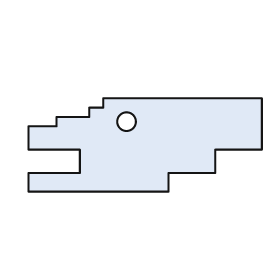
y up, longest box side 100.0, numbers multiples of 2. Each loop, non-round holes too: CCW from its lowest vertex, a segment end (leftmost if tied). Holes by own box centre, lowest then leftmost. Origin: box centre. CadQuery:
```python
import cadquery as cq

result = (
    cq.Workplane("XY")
    .moveTo(-50.0, -20.0)
    .lineTo(10.0, -20.0)
    .lineTo(10.0, -12.0)
    .lineTo(30.0, -12.0)
    .lineTo(30.0, -2.0)
    .lineTo(50.0, -2.0)
    .lineTo(50.0, 20.0)
    .lineTo(-18.0, 20.0)
    .lineTo(-18.0, 16.0)
    .lineTo(-24.0, 16.0)
    .lineTo(-24.0, 12.0)
    .lineTo(-38.0, 12.0)
    .lineTo(-38.0, 8.0)
    .lineTo(-50.0, 8.0)
    .lineTo(-50.0, -2.0)
    .lineTo(-28.0, -2.0)
    .lineTo(-28.0, -12.0)
    .lineTo(-50.0, -12.0)
    .close()
    .moveTo(-8.0, 10.0)
    .circle(4.0)
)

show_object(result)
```